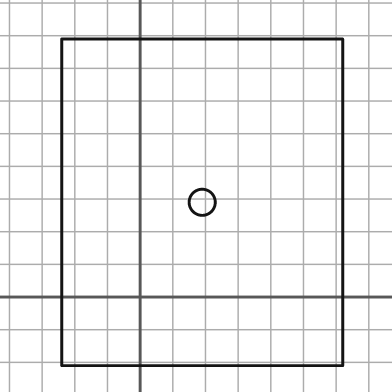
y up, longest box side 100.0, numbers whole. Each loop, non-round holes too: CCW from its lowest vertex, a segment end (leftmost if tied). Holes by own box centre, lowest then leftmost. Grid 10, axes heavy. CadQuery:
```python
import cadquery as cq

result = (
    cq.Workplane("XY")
    .moveTo(-24.0, -21.0)
    .lineTo(62.0, -21.0)
    .lineTo(62.0, 79.0)
    .lineTo(-24.0, 79.0)
    .close()
    .moveTo(19.0, 29.0)
    .circle(4.0)
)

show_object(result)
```